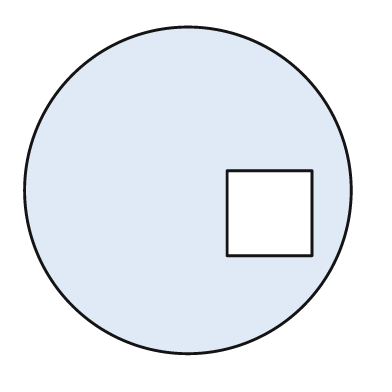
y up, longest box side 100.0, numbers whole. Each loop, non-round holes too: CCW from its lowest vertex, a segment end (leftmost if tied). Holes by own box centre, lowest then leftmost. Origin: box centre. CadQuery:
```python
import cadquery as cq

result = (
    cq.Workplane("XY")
    .moveTo(0.0, 0.0)
    .circle(50.0)
    .moveTo(12.0, -20.0)
    .lineTo(38.0, -20.0)
    .lineTo(38.0, 6.0)
    .lineTo(12.0, 6.0)
    .close()
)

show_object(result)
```